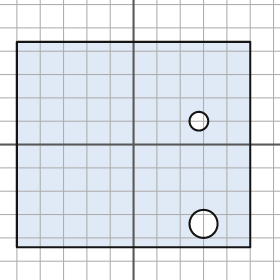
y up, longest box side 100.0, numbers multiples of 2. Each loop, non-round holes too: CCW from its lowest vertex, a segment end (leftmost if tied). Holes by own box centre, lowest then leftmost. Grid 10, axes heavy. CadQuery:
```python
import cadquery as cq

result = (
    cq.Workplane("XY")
    .moveTo(-50.0, -44.0)
    .lineTo(50.0, -44.0)
    .lineTo(50.0, 44.0)
    .lineTo(-50.0, 44.0)
    .close()
    .moveTo(30.0, -34.0)
    .circle(6.0)
    .moveTo(28.0, 10.0)
    .circle(4.0)
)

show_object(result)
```